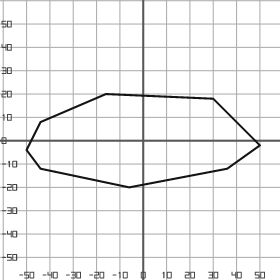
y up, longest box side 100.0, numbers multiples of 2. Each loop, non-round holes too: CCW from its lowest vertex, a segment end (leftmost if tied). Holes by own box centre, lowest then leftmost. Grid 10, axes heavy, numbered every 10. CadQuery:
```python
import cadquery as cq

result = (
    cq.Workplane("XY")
    .moveTo(-6.0, -20.0)
    .lineTo(36.0, -12.0)
    .lineTo(50.0, -2.0)
    .lineTo(30.0, 18.0)
    .lineTo(-16.0, 20.0)
    .lineTo(-44.0, 8.0)
    .lineTo(-50.0, -4.0)
    .lineTo(-44.0, -12.0)
    .close()
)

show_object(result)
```